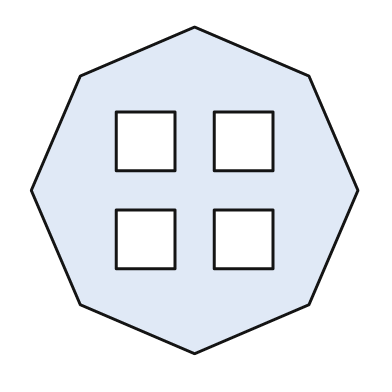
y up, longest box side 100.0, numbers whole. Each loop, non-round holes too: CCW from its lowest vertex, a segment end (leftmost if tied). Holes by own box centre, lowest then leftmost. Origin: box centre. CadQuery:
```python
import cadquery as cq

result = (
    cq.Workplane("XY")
    .moveTo(0.0, -50.0)
    .lineTo(35.0, -35.0)
    .lineTo(50.0, 0.0)
    .lineTo(35.0, 35.0)
    .lineTo(0.0, 50.0)
    .lineTo(-35.0, 35.0)
    .lineTo(-50.0, 0.0)
    .lineTo(-35.0, -35.0)
    .close()
    .moveTo(-24.0, -24.0)
    .lineTo(-6.0, -24.0)
    .lineTo(-6.0, -6.0)
    .lineTo(-24.0, -6.0)
    .close()
    .moveTo(6.0, -24.0)
    .lineTo(24.0, -24.0)
    .lineTo(24.0, -6.0)
    .lineTo(6.0, -6.0)
    .close()
    .moveTo(-24.0, 6.0)
    .lineTo(-6.0, 6.0)
    .lineTo(-6.0, 24.0)
    .lineTo(-24.0, 24.0)
    .close()
    .moveTo(6.0, 6.0)
    .lineTo(24.0, 6.0)
    .lineTo(24.0, 24.0)
    .lineTo(6.0, 24.0)
    .close()
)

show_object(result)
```